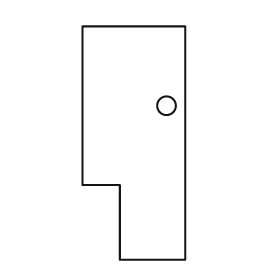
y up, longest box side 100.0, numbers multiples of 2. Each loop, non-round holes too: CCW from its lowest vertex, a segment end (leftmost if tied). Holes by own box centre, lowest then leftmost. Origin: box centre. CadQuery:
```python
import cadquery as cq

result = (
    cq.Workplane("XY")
    .moveTo(-6.0, -50.0)
    .lineTo(22.0, -50.0)
    .lineTo(22.0, 50.0)
    .lineTo(-22.0, 50.0)
    .lineTo(-22.0, -18.0)
    .lineTo(-6.0, -18.0)
    .close()
    .moveTo(14.0, 16.0)
    .circle(4.0)
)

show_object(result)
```